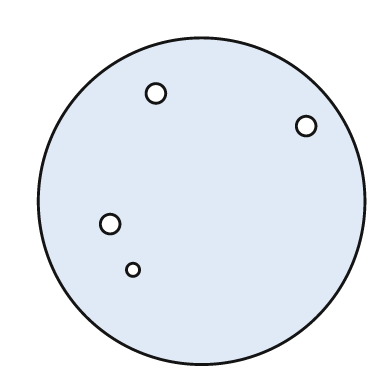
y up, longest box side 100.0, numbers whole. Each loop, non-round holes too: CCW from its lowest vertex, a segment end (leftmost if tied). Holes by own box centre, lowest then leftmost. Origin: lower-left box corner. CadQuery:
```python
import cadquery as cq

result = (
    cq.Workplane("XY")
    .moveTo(50.0, 50.0)
    .circle(50.0)
    .moveTo(29.0, 29.0)
    .circle(2.0)
    .moveTo(22.0, 43.0)
    .circle(3.0)
    .moveTo(82.0, 73.0)
    .circle(3.0)
    .moveTo(36.0, 83.0)
    .circle(3.0)
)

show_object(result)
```